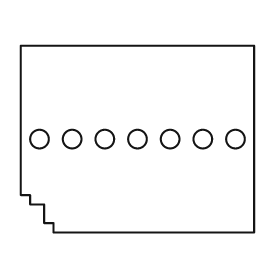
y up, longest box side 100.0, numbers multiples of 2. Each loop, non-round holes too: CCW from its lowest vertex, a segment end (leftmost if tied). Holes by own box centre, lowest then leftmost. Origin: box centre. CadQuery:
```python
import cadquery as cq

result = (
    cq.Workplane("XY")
    .moveTo(-36.0, -40.0)
    .lineTo(50.0, -40.0)
    .lineTo(50.0, 40.0)
    .lineTo(-50.0, 40.0)
    .lineTo(-50.0, -24.0)
    .lineTo(-46.0, -24.0)
    .lineTo(-46.0, -28.0)
    .lineTo(-40.0, -28.0)
    .lineTo(-40.0, -36.0)
    .lineTo(-36.0, -36.0)
    .close()
    .moveTo(-42.0, 0.0)
    .circle(4.0)
    .moveTo(-28.0, 0.0)
    .circle(4.0)
    .moveTo(-14.0, 0.0)
    .circle(4.0)
    .moveTo(0.0, 0.0)
    .circle(4.0)
    .moveTo(14.0, 0.0)
    .circle(4.0)
    .moveTo(28.0, 0.0)
    .circle(4.0)
    .moveTo(42.0, 0.0)
    .circle(4.0)
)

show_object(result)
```